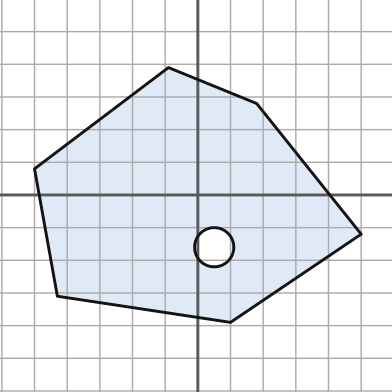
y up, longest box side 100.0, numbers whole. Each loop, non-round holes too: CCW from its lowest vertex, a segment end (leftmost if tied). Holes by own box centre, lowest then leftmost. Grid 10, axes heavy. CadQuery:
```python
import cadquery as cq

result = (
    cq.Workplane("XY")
    .moveTo(10.0, -39.0)
    .lineTo(50.0, -12.0)
    .lineTo(18.0, 28.0)
    .lineTo(-9.0, 39.0)
    .lineTo(-50.0, 8.0)
    .lineTo(-43.0, -31.0)
    .close()
    .moveTo(5.0, -16.0)
    .circle(6.0)
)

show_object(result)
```